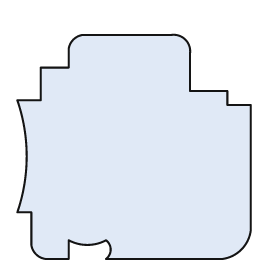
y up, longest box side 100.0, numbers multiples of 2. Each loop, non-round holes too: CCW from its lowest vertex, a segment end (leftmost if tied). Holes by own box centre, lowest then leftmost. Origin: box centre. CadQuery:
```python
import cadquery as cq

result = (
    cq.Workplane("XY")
    .moveTo(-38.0, -48.0)
    .lineTo(-28.0, -48.0)
    .lineTo(-28.0, -40.0)
    .threePointArc((-20.0, -42.0), (-12.0, -40.0))
    .threePointArc((-10.0, -44.0), (-12.0, -48.0))
    .lineTo(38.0, -48.0)
    .threePointArc((46.0, -44.0), (50.0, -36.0))
    .lineTo(50.0, 18.0)
    .lineTo(40.0, 18.0)
    .lineTo(40.0, 24.0)
    .lineTo(24.0, 24.0)
    .lineTo(24.0, 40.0)
    .threePointArc((22.0, 46.0), (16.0, 48.0))
    .lineTo(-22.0, 48.0)
    .threePointArc((-26.0, 46.0), (-28.0, 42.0))
    .lineTo(-28.0, 34.0)
    .lineTo(-40.0, 34.0)
    .lineTo(-40.0, 20.0)
    .lineTo(-50.0, 20.0)
    .threePointArc((-46.0, -4.0), (-50.0, -28.0))
    .lineTo(-44.0, -28.0)
    .lineTo(-44.0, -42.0)
    .threePointArc((-42.0, -46.0), (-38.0, -48.0))
    .close()
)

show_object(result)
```